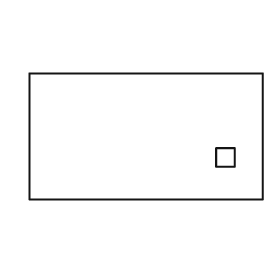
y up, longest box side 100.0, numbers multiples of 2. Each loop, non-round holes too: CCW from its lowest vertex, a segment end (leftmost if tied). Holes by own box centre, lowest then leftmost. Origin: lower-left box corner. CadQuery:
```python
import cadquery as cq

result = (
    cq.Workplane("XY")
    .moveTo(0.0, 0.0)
    .lineTo(100.0, 0.0)
    .lineTo(100.0, 54.0)
    .lineTo(0.0, 54.0)
    .close()
    .moveTo(80.0, 14.0)
    .lineTo(88.0, 14.0)
    .lineTo(88.0, 22.0)
    .lineTo(80.0, 22.0)
    .close()
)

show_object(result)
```